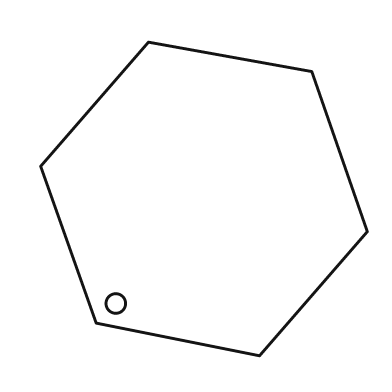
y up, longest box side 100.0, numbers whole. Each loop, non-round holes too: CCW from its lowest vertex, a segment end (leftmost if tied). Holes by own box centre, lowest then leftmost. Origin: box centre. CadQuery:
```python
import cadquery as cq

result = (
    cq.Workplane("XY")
    .moveTo(17.0, -48.0)
    .lineTo(50.0, -10.0)
    .lineTo(33.0, 39.0)
    .lineTo(-17.0, 48.0)
    .lineTo(-50.0, 10.0)
    .lineTo(-33.0, -38.0)
    .close()
    .moveTo(-27.0, -32.0)
    .circle(3.0)
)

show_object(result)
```